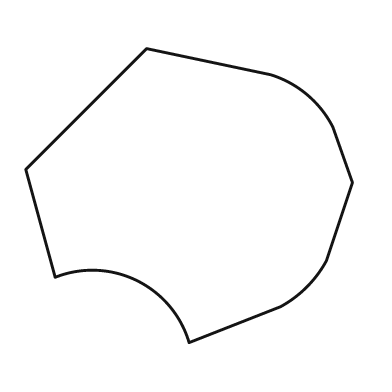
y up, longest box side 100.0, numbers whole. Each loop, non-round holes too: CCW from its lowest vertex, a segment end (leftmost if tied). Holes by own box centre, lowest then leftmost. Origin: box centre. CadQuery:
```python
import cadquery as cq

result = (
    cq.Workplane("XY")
    .moveTo(0.0, -45.0)
    .lineTo(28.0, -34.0)
    .threePointArc((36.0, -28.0), (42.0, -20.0))
    .lineTo(50.0, 4.0)
    .lineTo(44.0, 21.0)
    .threePointArc((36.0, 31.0), (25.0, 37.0))
    .lineTo(-13.0, 45.0)
    .lineTo(-50.0, 8.0)
    .lineTo(-41.0, -25.0)
    .threePointArc((-16.0, -26.0), (0.0, -45.0))
    .close()
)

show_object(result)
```